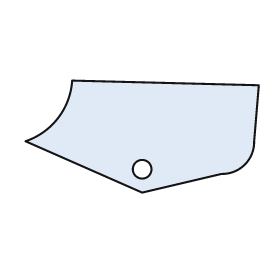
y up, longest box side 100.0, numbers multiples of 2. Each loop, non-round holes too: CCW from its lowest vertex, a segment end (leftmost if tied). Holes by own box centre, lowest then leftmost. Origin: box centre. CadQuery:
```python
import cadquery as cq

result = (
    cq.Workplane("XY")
    .moveTo(0.0, -24.0)
    .lineTo(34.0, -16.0)
    .threePointArc((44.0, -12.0), (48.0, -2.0))
    .lineTo(50.0, 22.0)
    .lineTo(-30.0, 24.0)
    .threePointArc((-36.0, 8.0), (-50.0, -2.0))
    .close()
    .moveTo(0.0, -14.0)
    .circle(4.0)
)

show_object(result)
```